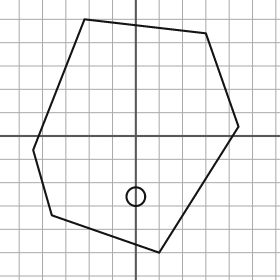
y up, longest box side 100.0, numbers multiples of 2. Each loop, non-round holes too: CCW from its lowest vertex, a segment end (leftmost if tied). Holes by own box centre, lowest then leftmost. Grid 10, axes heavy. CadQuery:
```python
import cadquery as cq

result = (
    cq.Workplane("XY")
    .moveTo(10.0, -50.0)
    .lineTo(44.0, 4.0)
    .lineTo(30.0, 44.0)
    .lineTo(-22.0, 50.0)
    .lineTo(-44.0, -6.0)
    .lineTo(-36.0, -34.0)
    .close()
    .moveTo(0.0, -26.0)
    .circle(4.0)
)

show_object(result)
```